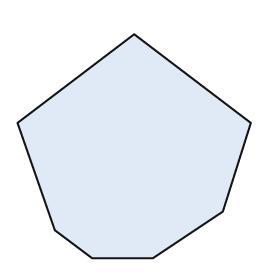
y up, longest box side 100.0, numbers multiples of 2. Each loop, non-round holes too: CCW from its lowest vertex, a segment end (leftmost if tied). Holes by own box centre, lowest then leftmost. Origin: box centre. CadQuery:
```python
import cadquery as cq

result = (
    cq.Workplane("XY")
    .moveTo(-18.0, -48.0)
    .lineTo(8.0, -48.0)
    .lineTo(38.0, -28.0)
    .lineTo(50.0, 10.0)
    .lineTo(0.0, 48.0)
    .lineTo(-50.0, 10.0)
    .lineTo(-34.0, -36.0)
    .close()
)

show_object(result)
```